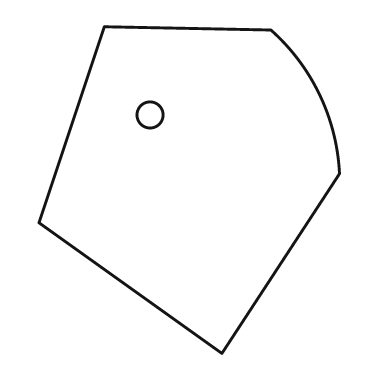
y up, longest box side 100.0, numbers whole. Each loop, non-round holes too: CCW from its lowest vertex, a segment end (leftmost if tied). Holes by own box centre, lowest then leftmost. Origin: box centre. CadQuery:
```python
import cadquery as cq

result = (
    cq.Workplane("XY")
    .moveTo(10.0, -50.0)
    .lineTo(46.0, 5.0)
    .threePointArc((40.0, 29.0), (25.0, 49.0))
    .lineTo(-26.0, 50.0)
    .lineTo(-46.0, -10.0)
    .close()
    .moveTo(-12.0, 23.0)
    .circle(4.0)
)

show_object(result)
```